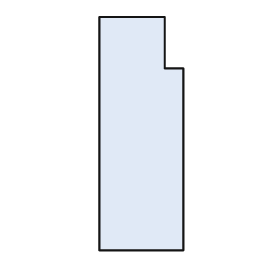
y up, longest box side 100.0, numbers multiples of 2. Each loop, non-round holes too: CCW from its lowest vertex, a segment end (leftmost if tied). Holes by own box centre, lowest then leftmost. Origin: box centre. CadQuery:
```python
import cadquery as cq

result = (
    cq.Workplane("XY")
    .moveTo(-18.0, -50.0)
    .lineTo(18.0, -50.0)
    .lineTo(18.0, 28.0)
    .lineTo(10.0, 28.0)
    .lineTo(10.0, 50.0)
    .lineTo(-18.0, 50.0)
    .close()
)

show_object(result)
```